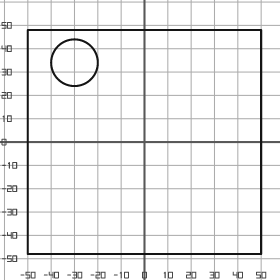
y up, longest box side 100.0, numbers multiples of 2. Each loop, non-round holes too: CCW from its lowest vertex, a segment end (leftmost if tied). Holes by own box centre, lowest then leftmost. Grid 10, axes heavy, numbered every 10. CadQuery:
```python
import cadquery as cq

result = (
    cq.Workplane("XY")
    .moveTo(-50.0, -48.0)
    .lineTo(50.0, -48.0)
    .lineTo(50.0, 48.0)
    .lineTo(-50.0, 48.0)
    .close()
    .moveTo(-30.0, 34.0)
    .circle(10.0)
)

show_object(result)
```